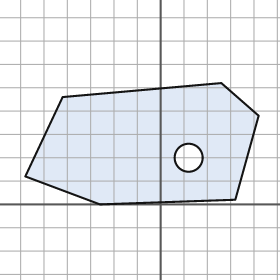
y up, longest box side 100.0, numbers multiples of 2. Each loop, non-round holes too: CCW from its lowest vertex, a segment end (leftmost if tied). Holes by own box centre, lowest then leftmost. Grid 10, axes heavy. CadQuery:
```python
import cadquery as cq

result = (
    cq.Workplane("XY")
    .moveTo(-26.0, 0.0)
    .lineTo(32.0, 2.0)
    .lineTo(42.0, 38.0)
    .lineTo(26.0, 52.0)
    .lineTo(-42.0, 46.0)
    .lineTo(-58.0, 12.0)
    .close()
    .moveTo(12.0, 20.0)
    .circle(6.0)
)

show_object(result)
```